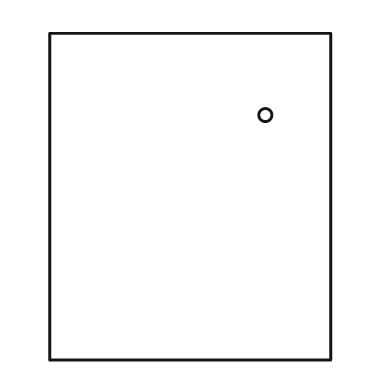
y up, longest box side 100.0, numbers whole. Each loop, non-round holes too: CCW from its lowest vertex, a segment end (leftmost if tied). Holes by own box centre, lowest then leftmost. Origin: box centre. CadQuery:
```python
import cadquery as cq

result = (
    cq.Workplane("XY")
    .moveTo(-43.0, -50.0)
    .lineTo(43.0, -50.0)
    .lineTo(43.0, 50.0)
    .lineTo(-43.0, 50.0)
    .close()
    .moveTo(23.0, 25.0)
    .circle(2.0)
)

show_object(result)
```